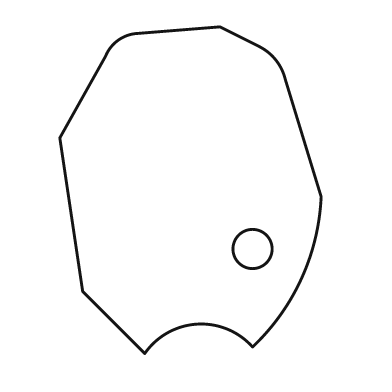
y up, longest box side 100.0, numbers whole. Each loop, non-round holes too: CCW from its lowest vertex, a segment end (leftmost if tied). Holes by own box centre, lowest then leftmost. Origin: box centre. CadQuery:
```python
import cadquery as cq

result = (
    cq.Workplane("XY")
    .moveTo(-14.0, -50.0)
    .threePointArc((2.0, -41.0), (19.0, -48.0))
    .threePointArc((34.0, -27.0), (40.0, -2.0))
    .lineTo(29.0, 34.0)
    .threePointArc((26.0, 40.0), (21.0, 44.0))
    .lineTo(9.0, 50.0)
    .lineTo(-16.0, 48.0)
    .threePointArc((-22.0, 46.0), (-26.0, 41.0))
    .lineTo(-40.0, 16.0)
    .lineTo(-33.0, -31.0)
    .close()
    .moveTo(19.0, -18.0)
    .circle(6.0)
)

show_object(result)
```